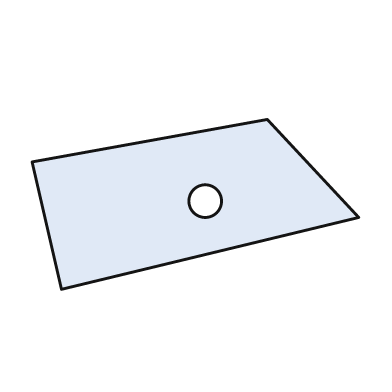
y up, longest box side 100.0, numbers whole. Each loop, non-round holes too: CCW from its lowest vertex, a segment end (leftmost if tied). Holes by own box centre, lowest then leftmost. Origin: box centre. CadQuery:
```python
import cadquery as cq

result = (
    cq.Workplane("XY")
    .moveTo(-41.0, -26.0)
    .lineTo(50.0, -4.0)
    .lineTo(22.0, 26.0)
    .lineTo(-50.0, 13.0)
    .close()
    .moveTo(3.0, 1.0)
    .circle(5.0)
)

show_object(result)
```